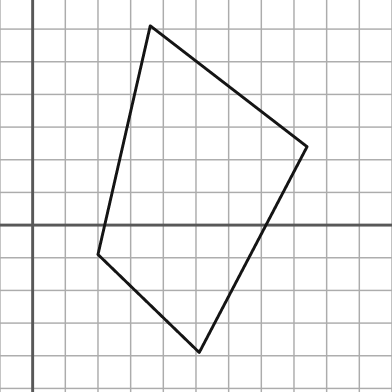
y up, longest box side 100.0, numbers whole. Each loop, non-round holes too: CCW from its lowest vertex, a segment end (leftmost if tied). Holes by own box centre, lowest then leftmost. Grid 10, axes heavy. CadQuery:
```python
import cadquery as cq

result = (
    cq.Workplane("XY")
    .moveTo(51.0, -39.0)
    .lineTo(84.0, 24.0)
    .lineTo(36.0, 61.0)
    .lineTo(20.0, -9.0)
    .close()
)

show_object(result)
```